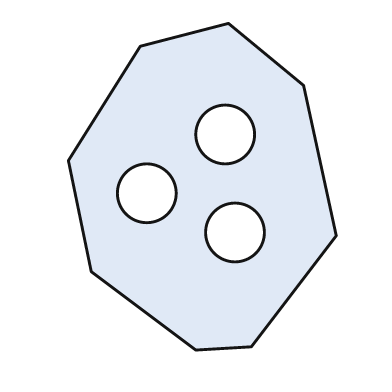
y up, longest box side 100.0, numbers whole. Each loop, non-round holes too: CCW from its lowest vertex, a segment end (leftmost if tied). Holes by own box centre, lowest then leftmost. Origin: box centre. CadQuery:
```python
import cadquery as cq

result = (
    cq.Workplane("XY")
    .moveTo(-2.0, -50.0)
    .lineTo(15.0, -49.0)
    .lineTo(41.0, -15.0)
    .lineTo(31.0, 31.0)
    .lineTo(8.0, 50.0)
    .lineTo(-19.0, 43.0)
    .lineTo(-41.0, 8.0)
    .lineTo(-34.0, -26.0)
    .close()
    .moveTo(10.0, -14.0)
    .circle(9.0)
    .moveTo(-17.0, -2.0)
    .circle(9.0)
    .moveTo(7.0, 16.0)
    .circle(9.0)
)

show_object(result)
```